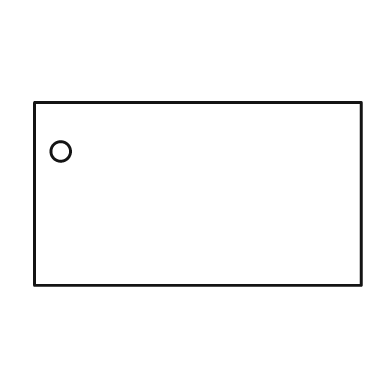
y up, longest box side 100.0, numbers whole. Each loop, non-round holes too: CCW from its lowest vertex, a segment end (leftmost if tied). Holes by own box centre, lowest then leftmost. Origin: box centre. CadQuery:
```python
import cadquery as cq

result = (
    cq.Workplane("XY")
    .moveTo(-50.0, -28.0)
    .lineTo(50.0, -28.0)
    .lineTo(50.0, 28.0)
    .lineTo(-50.0, 28.0)
    .close()
    .moveTo(-42.0, 13.0)
    .circle(3.0)
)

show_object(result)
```